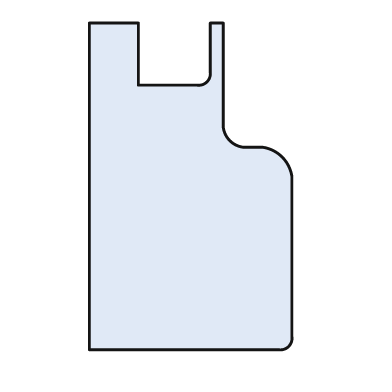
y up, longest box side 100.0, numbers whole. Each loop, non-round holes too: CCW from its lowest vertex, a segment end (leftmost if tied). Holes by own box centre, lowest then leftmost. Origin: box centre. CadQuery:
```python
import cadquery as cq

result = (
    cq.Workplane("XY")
    .moveTo(-31.0, -50.0)
    .lineTo(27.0, -50.0)
    .threePointArc((30.0, -49.0), (31.0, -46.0))
    .lineTo(31.0, 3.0)
    .threePointArc((28.0, 9.0), (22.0, 12.0))
    .lineTo(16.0, 12.0)
    .threePointArc((12.0, 14.0), (10.0, 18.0))
    .lineTo(10.0, 50.0)
    .lineTo(6.0, 50.0)
    .lineTo(6.0, 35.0)
    .threePointArc((5.0, 32.0), (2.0, 31.0))
    .lineTo(-16.0, 31.0)
    .lineTo(-16.0, 50.0)
    .lineTo(-31.0, 50.0)
    .close()
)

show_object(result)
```